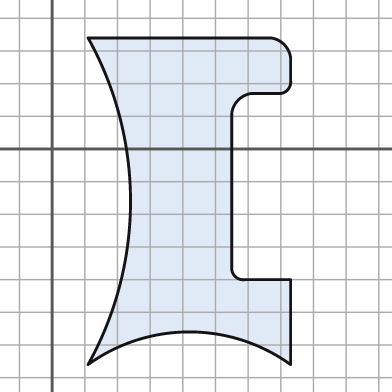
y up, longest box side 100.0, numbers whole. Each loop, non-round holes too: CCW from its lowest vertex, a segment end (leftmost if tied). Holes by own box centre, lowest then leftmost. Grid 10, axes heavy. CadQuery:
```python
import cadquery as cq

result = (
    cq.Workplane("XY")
    .moveTo(11.0, -66.0)
    .threePointArc((42.0, -56.0), (73.0, -66.0))
    .lineTo(73.0, -40.0)
    .lineTo(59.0, -40.0)
    .threePointArc((56.0, -39.0), (55.0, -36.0))
    .lineTo(55.0, 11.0)
    .threePointArc((57.0, 15.0), (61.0, 17.0))
    .lineTo(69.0, 17.0)
    .threePointArc((72.0, 18.0), (73.0, 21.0))
    .lineTo(73.0, 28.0)
    .threePointArc((71.0, 32.0), (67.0, 34.0))
    .lineTo(11.0, 34.0)
    .threePointArc((24.0, -16.0), (11.0, -66.0))
    .close()
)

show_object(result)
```